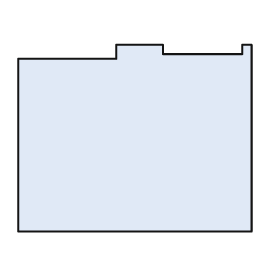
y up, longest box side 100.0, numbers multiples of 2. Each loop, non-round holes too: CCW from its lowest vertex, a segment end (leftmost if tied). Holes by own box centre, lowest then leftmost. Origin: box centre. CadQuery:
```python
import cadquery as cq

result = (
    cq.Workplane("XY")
    .moveTo(-50.0, -40.0)
    .lineTo(50.0, -40.0)
    .lineTo(50.0, 40.0)
    .lineTo(46.0, 40.0)
    .lineTo(46.0, 36.0)
    .lineTo(12.0, 36.0)
    .lineTo(12.0, 40.0)
    .lineTo(-8.0, 40.0)
    .lineTo(-8.0, 34.0)
    .lineTo(-50.0, 34.0)
    .close()
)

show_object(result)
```